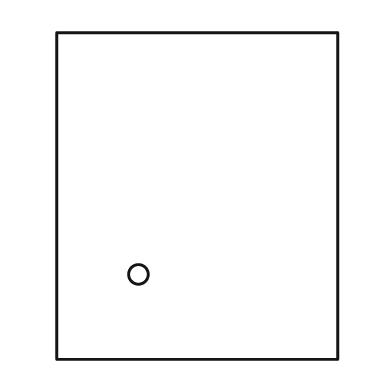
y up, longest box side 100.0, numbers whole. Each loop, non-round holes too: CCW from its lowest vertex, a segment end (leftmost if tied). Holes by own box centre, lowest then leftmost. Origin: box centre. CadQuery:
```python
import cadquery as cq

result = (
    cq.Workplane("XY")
    .moveTo(-43.0, -50.0)
    .lineTo(43.0, -50.0)
    .lineTo(43.0, 50.0)
    .lineTo(-43.0, 50.0)
    .close()
    .moveTo(-18.0, -24.0)
    .circle(3.0)
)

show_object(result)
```